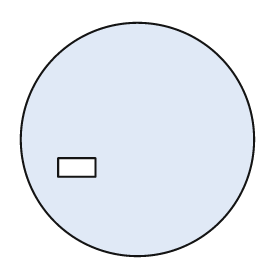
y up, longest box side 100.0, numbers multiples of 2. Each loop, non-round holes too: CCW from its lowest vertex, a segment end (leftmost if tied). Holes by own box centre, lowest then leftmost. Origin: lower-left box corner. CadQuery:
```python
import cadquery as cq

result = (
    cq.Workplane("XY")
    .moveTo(50.0, 50.0)
    .circle(50.0)
    .moveTo(16.0, 34.0)
    .lineTo(32.0, 34.0)
    .lineTo(32.0, 42.0)
    .lineTo(16.0, 42.0)
    .close()
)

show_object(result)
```